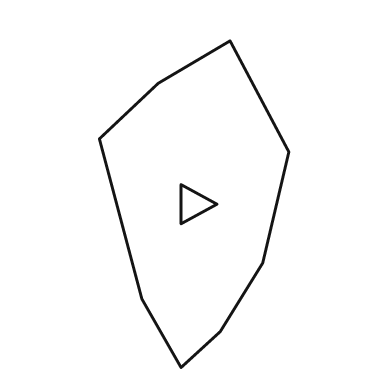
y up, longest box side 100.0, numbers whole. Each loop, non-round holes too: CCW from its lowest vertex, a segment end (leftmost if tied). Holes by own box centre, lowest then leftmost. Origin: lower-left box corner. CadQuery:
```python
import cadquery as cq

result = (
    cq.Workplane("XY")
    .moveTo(25.0, 0.0)
    .lineTo(37.0, 11.0)
    .lineTo(50.0, 32.0)
    .lineTo(58.0, 66.0)
    .lineTo(40.0, 100.0)
    .lineTo(18.0, 87.0)
    .lineTo(0.0, 70.0)
    .lineTo(13.0, 21.0)
    .close()
    .moveTo(25.0, 44.0)
    .lineTo(36.0, 50.0)
    .lineTo(25.0, 56.0)
    .close()
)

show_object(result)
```